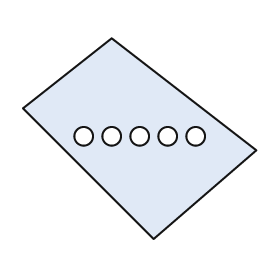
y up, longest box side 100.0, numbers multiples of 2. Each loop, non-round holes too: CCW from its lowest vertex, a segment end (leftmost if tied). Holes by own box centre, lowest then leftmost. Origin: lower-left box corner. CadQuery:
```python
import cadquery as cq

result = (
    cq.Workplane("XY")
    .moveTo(56.0, 0.0)
    .lineTo(100.0, 38.0)
    .lineTo(38.0, 86.0)
    .lineTo(0.0, 56.0)
    .close()
    .moveTo(26.0, 44.0)
    .circle(4.0)
    .moveTo(38.0, 44.0)
    .circle(4.0)
    .moveTo(50.0, 44.0)
    .circle(4.0)
    .moveTo(62.0, 44.0)
    .circle(4.0)
    .moveTo(74.0, 44.0)
    .circle(4.0)
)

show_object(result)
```